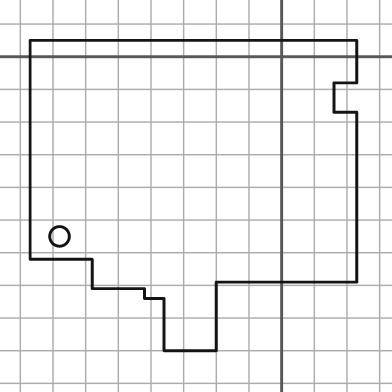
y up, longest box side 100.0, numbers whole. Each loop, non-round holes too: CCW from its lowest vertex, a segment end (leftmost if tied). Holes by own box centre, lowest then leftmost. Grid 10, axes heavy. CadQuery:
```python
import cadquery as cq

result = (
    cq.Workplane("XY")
    .moveTo(-36.0, -90.0)
    .lineTo(-20.0, -90.0)
    .lineTo(-20.0, -69.0)
    .lineTo(23.0, -69.0)
    .lineTo(23.0, -17.0)
    .lineTo(16.0, -17.0)
    .lineTo(16.0, -8.0)
    .lineTo(23.0, -8.0)
    .lineTo(23.0, 5.0)
    .lineTo(-77.0, 5.0)
    .lineTo(-77.0, -62.0)
    .lineTo(-58.0, -62.0)
    .lineTo(-58.0, -71.0)
    .lineTo(-42.0, -71.0)
    .lineTo(-42.0, -74.0)
    .lineTo(-36.0, -74.0)
    .close()
    .moveTo(-68.0, -55.0)
    .circle(3.0)
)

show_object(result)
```